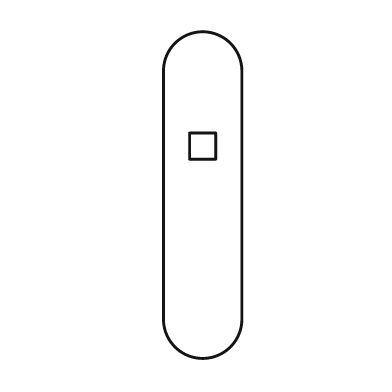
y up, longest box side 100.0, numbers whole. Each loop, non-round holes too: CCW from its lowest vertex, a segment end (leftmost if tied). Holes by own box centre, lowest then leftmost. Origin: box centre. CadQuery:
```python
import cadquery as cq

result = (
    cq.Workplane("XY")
    .moveTo(-12.0, -38.0)
    .threePointArc((0.0, -50.0), (12.0, -38.0))
    .lineTo(12.0, 38.0)
    .threePointArc((0.0, 50.0), (-12.0, 38.0))
    .close()
    .moveTo(-4.0, 11.0)
    .lineTo(4.0, 11.0)
    .lineTo(4.0, 19.0)
    .lineTo(-4.0, 19.0)
    .close()
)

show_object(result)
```